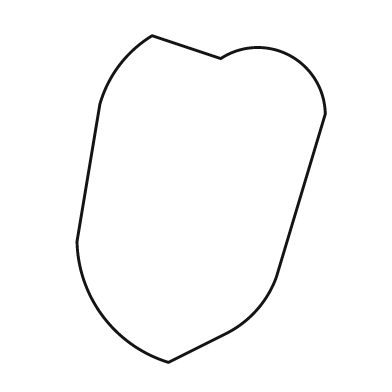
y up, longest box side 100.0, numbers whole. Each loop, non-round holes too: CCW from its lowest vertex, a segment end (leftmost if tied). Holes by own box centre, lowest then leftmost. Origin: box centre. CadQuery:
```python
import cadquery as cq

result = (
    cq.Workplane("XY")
    .moveTo(-10.0, -50.0)
    .lineTo(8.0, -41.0)
    .threePointArc((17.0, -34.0), (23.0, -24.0))
    .lineTo(38.0, 26.0)
    .threePointArc((27.0, 44.0), (6.0, 43.0))
    .lineTo(-15.0, 50.0)
    .threePointArc((-25.0, 41.0), (-31.0, 29.0))
    .lineTo(-38.0, -13.0)
    .threePointArc((-30.0, -36.0), (-10.0, -50.0))
    .close()
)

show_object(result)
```